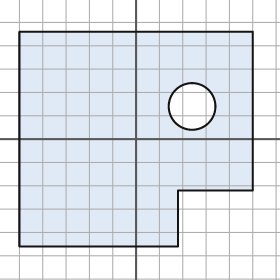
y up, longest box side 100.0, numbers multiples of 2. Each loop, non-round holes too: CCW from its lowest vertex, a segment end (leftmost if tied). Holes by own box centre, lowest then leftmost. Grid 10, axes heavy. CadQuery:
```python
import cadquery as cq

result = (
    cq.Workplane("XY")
    .moveTo(-50.0, -46.0)
    .lineTo(18.0, -46.0)
    .lineTo(18.0, -22.0)
    .lineTo(50.0, -22.0)
    .lineTo(50.0, 46.0)
    .lineTo(-50.0, 46.0)
    .close()
    .moveTo(24.0, 14.0)
    .circle(10.0)
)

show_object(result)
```